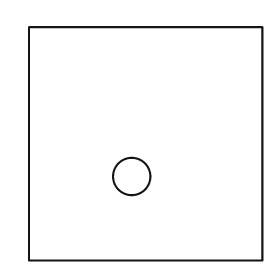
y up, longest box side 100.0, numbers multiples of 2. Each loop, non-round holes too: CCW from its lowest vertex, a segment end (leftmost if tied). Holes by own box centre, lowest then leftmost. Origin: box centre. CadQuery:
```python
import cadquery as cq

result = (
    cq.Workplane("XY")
    .moveTo(-50.0, -50.0)
    .lineTo(50.0, -50.0)
    .lineTo(50.0, 50.0)
    .lineTo(-50.0, 50.0)
    .close()
    .moveTo(-6.0, -14.0)
    .circle(8.0)
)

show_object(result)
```